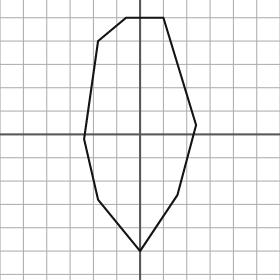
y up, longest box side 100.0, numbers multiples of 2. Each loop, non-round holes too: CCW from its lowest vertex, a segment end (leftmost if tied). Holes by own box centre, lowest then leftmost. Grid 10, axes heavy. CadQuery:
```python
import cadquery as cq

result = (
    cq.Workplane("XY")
    .moveTo(0.0, -50.0)
    .lineTo(16.0, -26.0)
    .lineTo(24.0, 4.0)
    .lineTo(10.0, 50.0)
    .lineTo(-6.0, 50.0)
    .lineTo(-18.0, 40.0)
    .lineTo(-24.0, -2.0)
    .lineTo(-18.0, -28.0)
    .close()
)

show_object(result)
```